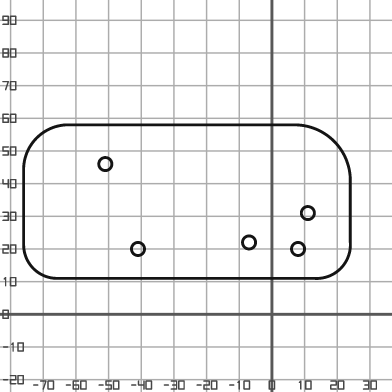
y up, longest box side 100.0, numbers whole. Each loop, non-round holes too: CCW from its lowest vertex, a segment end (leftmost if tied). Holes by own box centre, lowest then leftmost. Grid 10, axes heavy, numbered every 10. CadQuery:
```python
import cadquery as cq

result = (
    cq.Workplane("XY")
    .moveTo(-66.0, 11.0)
    .lineTo(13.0, 11.0)
    .threePointArc((21.0, 14.0), (24.0, 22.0))
    .lineTo(24.0, 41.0)
    .threePointArc((19.0, 53.0), (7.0, 58.0))
    .lineTo(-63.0, 58.0)
    .threePointArc((-72.0, 54.0), (-76.0, 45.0))
    .lineTo(-76.0, 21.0)
    .threePointArc((-73.0, 14.0), (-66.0, 11.0))
    .close()
    .moveTo(-41.0, 20.0)
    .circle(2.0)
    .moveTo(8.0, 20.0)
    .circle(2.0)
    .moveTo(-7.0, 22.0)
    .circle(2.0)
    .moveTo(11.0, 31.0)
    .circle(2.0)
    .moveTo(-51.0, 46.0)
    .circle(2.0)
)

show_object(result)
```